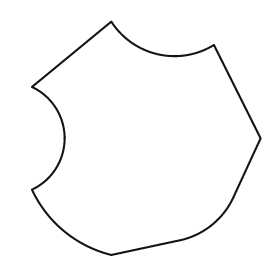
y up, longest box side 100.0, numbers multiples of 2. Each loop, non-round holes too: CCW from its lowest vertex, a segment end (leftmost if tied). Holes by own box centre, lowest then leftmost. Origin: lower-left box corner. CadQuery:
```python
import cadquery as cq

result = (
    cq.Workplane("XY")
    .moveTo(34.0, 0.0)
    .lineTo(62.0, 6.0)
    .threePointArc((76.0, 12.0), (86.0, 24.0))
    .lineTo(98.0, 50.0)
    .lineTo(78.0, 90.0)
    .threePointArc((54.0, 86.0), (34.0, 100.0))
    .lineTo(0.0, 72.0)
    .threePointArc((14.0, 50.0), (0.0, 28.0))
    .threePointArc((14.0, 10.0), (34.0, 0.0))
    .close()
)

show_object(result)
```